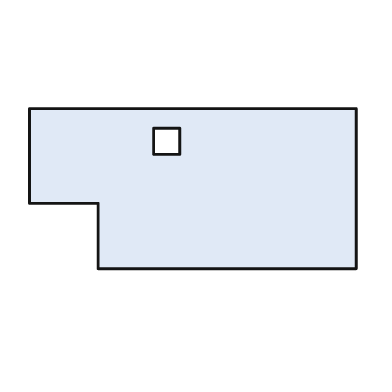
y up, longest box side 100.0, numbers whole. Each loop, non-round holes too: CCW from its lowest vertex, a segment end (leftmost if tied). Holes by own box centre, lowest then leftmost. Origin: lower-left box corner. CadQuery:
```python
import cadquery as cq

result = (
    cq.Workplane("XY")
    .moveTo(21.0, 0.0)
    .lineTo(100.0, 0.0)
    .lineTo(100.0, 49.0)
    .lineTo(0.0, 49.0)
    .lineTo(0.0, 20.0)
    .lineTo(21.0, 20.0)
    .close()
    .moveTo(38.0, 35.0)
    .lineTo(46.0, 35.0)
    .lineTo(46.0, 43.0)
    .lineTo(38.0, 43.0)
    .close()
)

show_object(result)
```